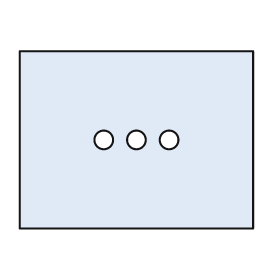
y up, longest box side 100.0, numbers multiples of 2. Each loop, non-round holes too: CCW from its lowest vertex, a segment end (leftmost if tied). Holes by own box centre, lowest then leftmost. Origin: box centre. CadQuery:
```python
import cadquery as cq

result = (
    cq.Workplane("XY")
    .moveTo(-50.0, -38.0)
    .lineTo(50.0, -38.0)
    .lineTo(50.0, 38.0)
    .lineTo(-50.0, 38.0)
    .close()
    .moveTo(-14.0, 0.0)
    .circle(4.0)
    .moveTo(0.0, 0.0)
    .circle(4.0)
    .moveTo(14.0, 0.0)
    .circle(4.0)
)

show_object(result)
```